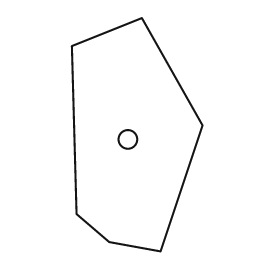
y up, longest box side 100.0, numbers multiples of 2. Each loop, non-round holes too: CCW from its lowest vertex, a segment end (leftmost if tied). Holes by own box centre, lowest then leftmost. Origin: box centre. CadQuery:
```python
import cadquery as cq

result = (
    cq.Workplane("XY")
    .moveTo(10.0, -50.0)
    .lineTo(28.0, 4.0)
    .lineTo(2.0, 50.0)
    .lineTo(-28.0, 38.0)
    .lineTo(-26.0, -34.0)
    .lineTo(-12.0, -46.0)
    .close()
    .moveTo(-4.0, -2.0)
    .circle(4.0)
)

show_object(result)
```